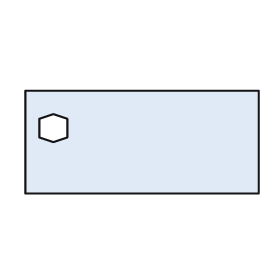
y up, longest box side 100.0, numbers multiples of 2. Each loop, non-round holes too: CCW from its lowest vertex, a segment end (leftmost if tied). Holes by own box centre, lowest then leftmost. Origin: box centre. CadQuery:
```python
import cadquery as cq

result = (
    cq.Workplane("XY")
    .moveTo(-50.0, -22.0)
    .lineTo(50.0, -22.0)
    .lineTo(50.0, 22.0)
    .lineTo(-50.0, 22.0)
    .close()
    .moveTo(-38.0, 0.0)
    .lineTo(-32.0, 2.0)
    .lineTo(-32.0, 10.0)
    .lineTo(-38.0, 12.0)
    .lineTo(-44.0, 10.0)
    .lineTo(-44.0, 2.0)
    .close()
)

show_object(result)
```